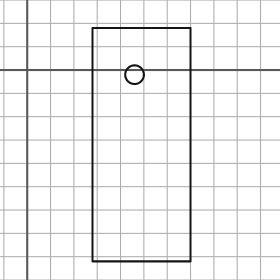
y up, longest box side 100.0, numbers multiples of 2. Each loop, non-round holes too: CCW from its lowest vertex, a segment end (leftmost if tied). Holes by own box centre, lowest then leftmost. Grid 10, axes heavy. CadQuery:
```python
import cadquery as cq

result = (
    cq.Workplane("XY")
    .moveTo(28.0, -82.0)
    .lineTo(70.0, -82.0)
    .lineTo(70.0, 18.0)
    .lineTo(28.0, 18.0)
    .close()
    .moveTo(46.0, -2.0)
    .circle(4.0)
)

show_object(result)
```